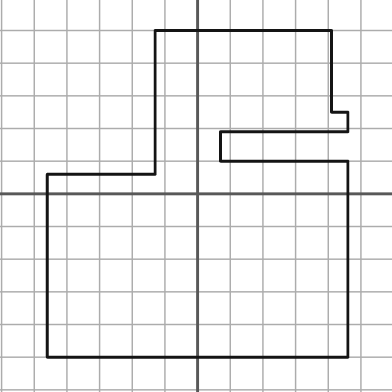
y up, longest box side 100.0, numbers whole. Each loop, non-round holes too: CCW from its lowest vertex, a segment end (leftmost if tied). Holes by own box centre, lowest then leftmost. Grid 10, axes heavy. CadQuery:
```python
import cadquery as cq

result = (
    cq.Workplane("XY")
    .moveTo(-46.0, -50.0)
    .lineTo(46.0, -50.0)
    .lineTo(46.0, 10.0)
    .lineTo(7.0, 10.0)
    .lineTo(7.0, 19.0)
    .lineTo(46.0, 19.0)
    .lineTo(46.0, 25.0)
    .lineTo(41.0, 25.0)
    .lineTo(41.0, 50.0)
    .lineTo(-13.0, 50.0)
    .lineTo(-13.0, 6.0)
    .lineTo(-46.0, 6.0)
    .close()
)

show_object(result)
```